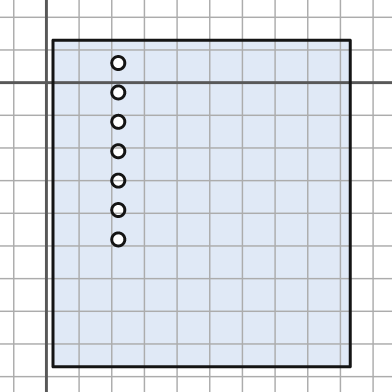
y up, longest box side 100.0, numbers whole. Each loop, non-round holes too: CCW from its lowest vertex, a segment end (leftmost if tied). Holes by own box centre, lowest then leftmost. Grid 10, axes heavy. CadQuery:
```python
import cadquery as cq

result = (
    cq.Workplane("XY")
    .moveTo(2.0, -87.0)
    .lineTo(93.0, -87.0)
    .lineTo(93.0, 13.0)
    .lineTo(2.0, 13.0)
    .close()
    .moveTo(22.0, -48.0)
    .circle(2.0)
    .moveTo(22.0, -39.0)
    .circle(2.0)
    .moveTo(22.0, -30.0)
    .circle(2.0)
    .moveTo(22.0, -21.0)
    .circle(2.0)
    .moveTo(22.0, -12.0)
    .circle(2.0)
    .moveTo(22.0, -3.0)
    .circle(2.0)
    .moveTo(22.0, 6.0)
    .circle(2.0)
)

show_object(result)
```